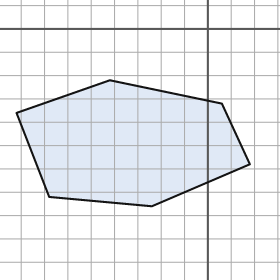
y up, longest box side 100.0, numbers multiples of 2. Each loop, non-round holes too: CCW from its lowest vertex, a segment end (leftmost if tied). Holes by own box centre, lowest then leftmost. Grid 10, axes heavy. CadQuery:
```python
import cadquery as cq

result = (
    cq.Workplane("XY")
    .moveTo(-24.0, -76.0)
    .lineTo(18.0, -58.0)
    .lineTo(6.0, -32.0)
    .lineTo(-42.0, -22.0)
    .lineTo(-82.0, -36.0)
    .lineTo(-68.0, -72.0)
    .close()
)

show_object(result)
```